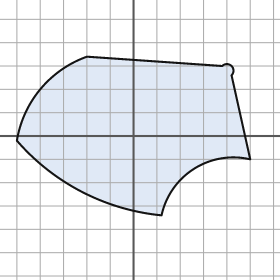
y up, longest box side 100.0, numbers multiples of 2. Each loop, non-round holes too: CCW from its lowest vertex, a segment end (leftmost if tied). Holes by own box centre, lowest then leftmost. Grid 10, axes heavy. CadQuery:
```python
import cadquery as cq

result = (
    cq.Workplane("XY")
    .moveTo(12.0, -34.0)
    .threePointArc((26.0, -14.0), (50.0, -10.0))
    .lineTo(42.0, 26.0)
    .threePointArc((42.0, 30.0), (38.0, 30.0))
    .lineTo(-20.0, 34.0)
    .threePointArc((-40.0, 20.0), (-50.0, -2.0))
    .threePointArc((-22.0, -24.0), (12.0, -34.0))
    .close()
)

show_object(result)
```